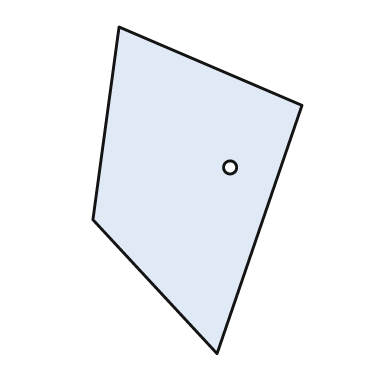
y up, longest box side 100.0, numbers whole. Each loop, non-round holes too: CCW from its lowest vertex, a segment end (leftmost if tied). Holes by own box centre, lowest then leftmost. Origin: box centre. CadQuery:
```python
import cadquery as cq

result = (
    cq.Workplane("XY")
    .moveTo(6.0, -50.0)
    .lineTo(32.0, 26.0)
    .lineTo(-24.0, 50.0)
    .lineTo(-32.0, -9.0)
    .close()
    .moveTo(10.0, 7.0)
    .circle(2.0)
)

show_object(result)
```